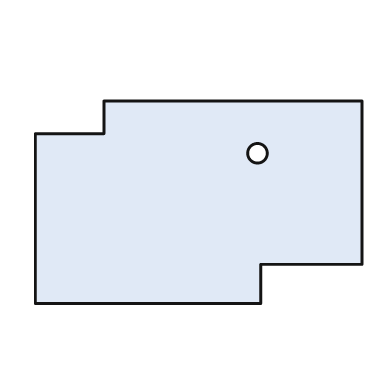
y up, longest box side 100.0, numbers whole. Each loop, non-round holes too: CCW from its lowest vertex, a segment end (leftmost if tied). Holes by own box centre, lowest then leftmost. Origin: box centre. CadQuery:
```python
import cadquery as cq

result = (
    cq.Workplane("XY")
    .moveTo(-50.0, -31.0)
    .lineTo(19.0, -31.0)
    .lineTo(19.0, -19.0)
    .lineTo(50.0, -19.0)
    .lineTo(50.0, 31.0)
    .lineTo(-29.0, 31.0)
    .lineTo(-29.0, 21.0)
    .lineTo(-50.0, 21.0)
    .close()
    .moveTo(18.0, 15.0)
    .circle(3.0)
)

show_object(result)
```